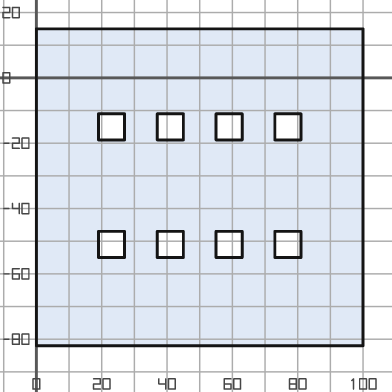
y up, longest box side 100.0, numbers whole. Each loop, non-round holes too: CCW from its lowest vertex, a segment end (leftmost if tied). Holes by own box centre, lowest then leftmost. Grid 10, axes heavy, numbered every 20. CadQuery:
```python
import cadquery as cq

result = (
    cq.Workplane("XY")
    .moveTo(0.0, -82.0)
    .lineTo(100.0, -82.0)
    .lineTo(100.0, 15.0)
    .lineTo(0.0, 15.0)
    .close()
    .moveTo(19.0, -55.0)
    .lineTo(27.0, -55.0)
    .lineTo(27.0, -47.0)
    .lineTo(19.0, -47.0)
    .close()
    .moveTo(37.0, -55.0)
    .lineTo(45.0, -55.0)
    .lineTo(45.0, -47.0)
    .lineTo(37.0, -47.0)
    .close()
    .moveTo(55.0, -55.0)
    .lineTo(63.0, -55.0)
    .lineTo(63.0, -47.0)
    .lineTo(55.0, -47.0)
    .close()
    .moveTo(73.0, -55.0)
    .lineTo(81.0, -55.0)
    .lineTo(81.0, -47.0)
    .lineTo(73.0, -47.0)
    .close()
    .moveTo(19.0, -19.0)
    .lineTo(27.0, -19.0)
    .lineTo(27.0, -11.0)
    .lineTo(19.0, -11.0)
    .close()
    .moveTo(37.0, -19.0)
    .lineTo(45.0, -19.0)
    .lineTo(45.0, -11.0)
    .lineTo(37.0, -11.0)
    .close()
    .moveTo(55.0, -19.0)
    .lineTo(63.0, -19.0)
    .lineTo(63.0, -11.0)
    .lineTo(55.0, -11.0)
    .close()
    .moveTo(73.0, -19.0)
    .lineTo(81.0, -19.0)
    .lineTo(81.0, -11.0)
    .lineTo(73.0, -11.0)
    .close()
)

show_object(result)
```